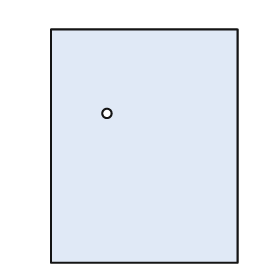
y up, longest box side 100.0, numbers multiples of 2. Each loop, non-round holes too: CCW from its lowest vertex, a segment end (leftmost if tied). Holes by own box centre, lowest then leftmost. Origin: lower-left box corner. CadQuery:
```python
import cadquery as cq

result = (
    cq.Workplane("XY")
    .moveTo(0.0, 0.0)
    .lineTo(80.0, 0.0)
    .lineTo(80.0, 100.0)
    .lineTo(0.0, 100.0)
    .close()
    .moveTo(24.0, 64.0)
    .circle(2.0)
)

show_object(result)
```